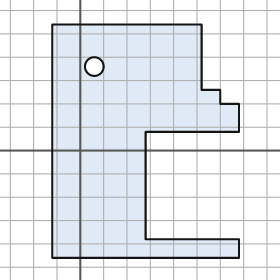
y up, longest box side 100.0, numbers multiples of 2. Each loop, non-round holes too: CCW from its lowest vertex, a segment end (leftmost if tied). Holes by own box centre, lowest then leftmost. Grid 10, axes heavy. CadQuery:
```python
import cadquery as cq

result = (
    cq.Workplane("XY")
    .moveTo(-12.0, -46.0)
    .lineTo(68.0, -46.0)
    .lineTo(68.0, -38.0)
    .lineTo(28.0, -38.0)
    .lineTo(28.0, 8.0)
    .lineTo(68.0, 8.0)
    .lineTo(68.0, 20.0)
    .lineTo(60.0, 20.0)
    .lineTo(60.0, 26.0)
    .lineTo(52.0, 26.0)
    .lineTo(52.0, 54.0)
    .lineTo(-12.0, 54.0)
    .close()
    .moveTo(6.0, 36.0)
    .circle(4.0)
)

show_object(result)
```